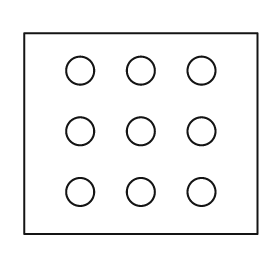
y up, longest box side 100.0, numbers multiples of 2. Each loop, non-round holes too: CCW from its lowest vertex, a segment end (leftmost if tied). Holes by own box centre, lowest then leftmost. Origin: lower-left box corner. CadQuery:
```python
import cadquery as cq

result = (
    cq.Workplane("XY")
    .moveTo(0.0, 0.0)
    .lineTo(100.0, 0.0)
    .lineTo(100.0, 86.0)
    .lineTo(0.0, 86.0)
    .close()
    .moveTo(24.0, 18.0)
    .circle(6.0)
    .moveTo(50.0, 18.0)
    .circle(6.0)
    .moveTo(76.0, 18.0)
    .circle(6.0)
    .moveTo(24.0, 44.0)
    .circle(6.0)
    .moveTo(50.0, 44.0)
    .circle(6.0)
    .moveTo(76.0, 44.0)
    .circle(6.0)
    .moveTo(24.0, 70.0)
    .circle(6.0)
    .moveTo(50.0, 70.0)
    .circle(6.0)
    .moveTo(76.0, 70.0)
    .circle(6.0)
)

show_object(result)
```